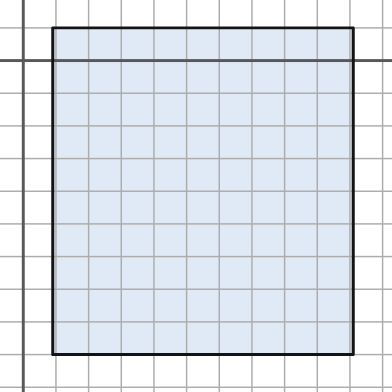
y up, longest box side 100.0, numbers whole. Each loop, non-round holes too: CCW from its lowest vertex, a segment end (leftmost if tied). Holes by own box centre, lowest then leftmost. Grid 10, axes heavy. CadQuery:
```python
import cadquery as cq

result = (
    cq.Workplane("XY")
    .moveTo(9.0, -90.0)
    .lineTo(101.0, -90.0)
    .lineTo(101.0, 10.0)
    .lineTo(9.0, 10.0)
    .close()
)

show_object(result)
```